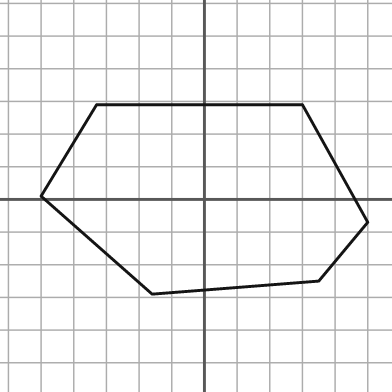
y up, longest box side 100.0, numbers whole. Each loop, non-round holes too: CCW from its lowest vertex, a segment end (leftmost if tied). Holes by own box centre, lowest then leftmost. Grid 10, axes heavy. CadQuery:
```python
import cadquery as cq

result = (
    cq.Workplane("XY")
    .moveTo(-16.0, -29.0)
    .lineTo(35.0, -25.0)
    .lineTo(50.0, -7.0)
    .lineTo(30.0, 29.0)
    .lineTo(-33.0, 29.0)
    .lineTo(-50.0, 1.0)
    .close()
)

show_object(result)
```